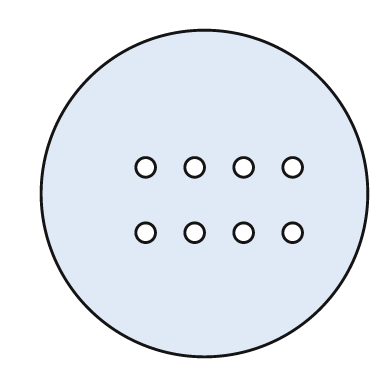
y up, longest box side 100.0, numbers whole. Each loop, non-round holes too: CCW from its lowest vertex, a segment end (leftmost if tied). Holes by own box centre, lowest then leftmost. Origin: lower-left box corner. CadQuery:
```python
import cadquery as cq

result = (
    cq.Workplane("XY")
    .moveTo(50.0, 50.0)
    .circle(50.0)
    .moveTo(32.0, 38.0)
    .circle(3.0)
    .moveTo(47.0, 38.0)
    .circle(3.0)
    .moveTo(62.0, 38.0)
    .circle(3.0)
    .moveTo(77.0, 38.0)
    .circle(3.0)
    .moveTo(32.0, 58.0)
    .circle(3.0)
    .moveTo(47.0, 58.0)
    .circle(3.0)
    .moveTo(62.0, 58.0)
    .circle(3.0)
    .moveTo(77.0, 58.0)
    .circle(3.0)
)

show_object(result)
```